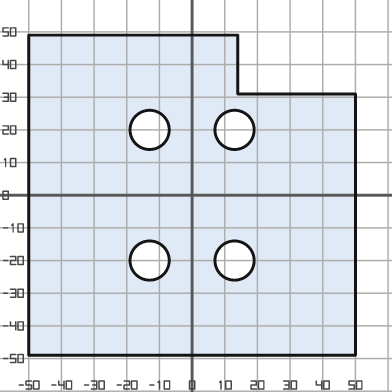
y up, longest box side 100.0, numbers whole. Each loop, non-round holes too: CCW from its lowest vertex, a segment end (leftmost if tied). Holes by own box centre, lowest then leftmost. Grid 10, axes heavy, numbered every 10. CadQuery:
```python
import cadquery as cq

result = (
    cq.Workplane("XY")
    .moveTo(-50.0, -49.0)
    .lineTo(50.0, -49.0)
    .lineTo(50.0, 31.0)
    .lineTo(14.0, 31.0)
    .lineTo(14.0, 49.0)
    .lineTo(-50.0, 49.0)
    .close()
    .moveTo(-13.0, -20.0)
    .circle(6.0)
    .moveTo(13.0, -20.0)
    .circle(6.0)
    .moveTo(-13.0, 20.0)
    .circle(6.0)
    .moveTo(13.0, 20.0)
    .circle(6.0)
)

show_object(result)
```